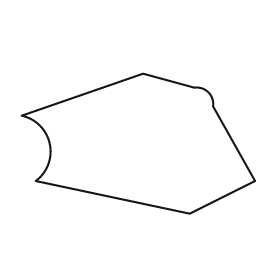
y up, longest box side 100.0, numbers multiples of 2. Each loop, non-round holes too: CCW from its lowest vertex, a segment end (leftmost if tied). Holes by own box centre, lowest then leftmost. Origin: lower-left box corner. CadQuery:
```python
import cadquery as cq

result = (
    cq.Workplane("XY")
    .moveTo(72.0, 0.0)
    .lineTo(100.0, 14.0)
    .lineTo(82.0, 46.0)
    .threePointArc((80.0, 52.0), (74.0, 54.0))
    .lineTo(52.0, 60.0)
    .lineTo(0.0, 42.0)
    .threePointArc((12.0, 30.0), (6.0, 14.0))
    .close()
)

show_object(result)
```